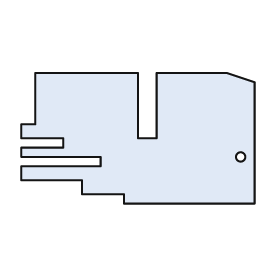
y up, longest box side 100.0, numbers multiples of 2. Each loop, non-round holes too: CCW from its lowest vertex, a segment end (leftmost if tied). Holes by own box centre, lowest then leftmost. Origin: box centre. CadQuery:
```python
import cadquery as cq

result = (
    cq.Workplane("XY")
    .moveTo(-6.0, -28.0)
    .lineTo(50.0, -28.0)
    .lineTo(50.0, 24.0)
    .lineTo(38.0, 28.0)
    .lineTo(8.0, 28.0)
    .lineTo(8.0, 0.0)
    .lineTo(0.0, 0.0)
    .lineTo(0.0, 28.0)
    .lineTo(-44.0, 28.0)
    .lineTo(-44.0, 6.0)
    .lineTo(-50.0, 6.0)
    .lineTo(-50.0, 0.0)
    .lineTo(-32.0, 0.0)
    .lineTo(-32.0, -4.0)
    .lineTo(-50.0, -4.0)
    .lineTo(-50.0, -8.0)
    .lineTo(-16.0, -8.0)
    .lineTo(-16.0, -12.0)
    .lineTo(-50.0, -12.0)
    .lineTo(-50.0, -18.0)
    .lineTo(-24.0, -18.0)
    .lineTo(-24.0, -24.0)
    .lineTo(-6.0, -24.0)
    .close()
    .moveTo(44.0, -8.0)
    .circle(2.0)
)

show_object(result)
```